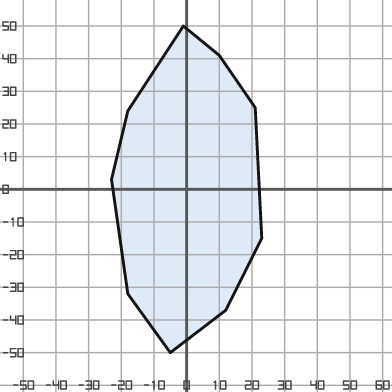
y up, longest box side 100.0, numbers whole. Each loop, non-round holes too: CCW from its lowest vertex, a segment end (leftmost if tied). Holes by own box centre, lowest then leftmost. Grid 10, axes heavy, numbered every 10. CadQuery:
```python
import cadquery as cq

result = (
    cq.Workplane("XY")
    .moveTo(-5.0, -50.0)
    .lineTo(12.0, -37.0)
    .lineTo(23.0, -15.0)
    .lineTo(21.0, 25.0)
    .lineTo(10.0, 41.0)
    .lineTo(-1.0, 50.0)
    .lineTo(-18.0, 24.0)
    .lineTo(-23.0, 3.0)
    .lineTo(-18.0, -32.0)
    .close()
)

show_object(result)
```